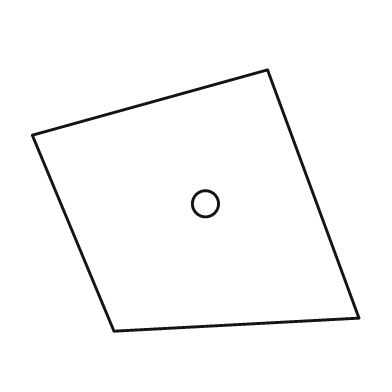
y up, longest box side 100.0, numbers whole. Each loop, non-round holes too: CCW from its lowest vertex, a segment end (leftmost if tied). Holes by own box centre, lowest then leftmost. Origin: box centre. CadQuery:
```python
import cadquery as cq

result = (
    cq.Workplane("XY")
    .moveTo(-25.0, -40.0)
    .lineTo(50.0, -36.0)
    .lineTo(22.0, 40.0)
    .lineTo(-50.0, 20.0)
    .close()
    .moveTo(3.0, -1.0)
    .circle(4.0)
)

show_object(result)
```